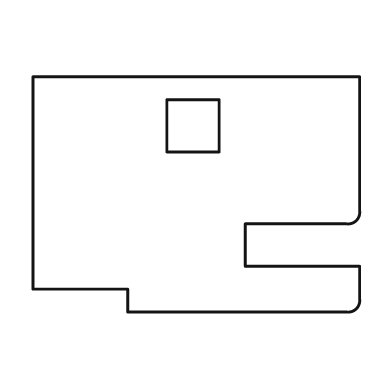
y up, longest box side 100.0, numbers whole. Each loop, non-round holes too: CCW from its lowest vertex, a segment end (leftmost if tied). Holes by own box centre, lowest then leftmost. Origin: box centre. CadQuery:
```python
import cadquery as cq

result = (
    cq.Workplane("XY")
    .moveTo(-21.0, -36.0)
    .lineTo(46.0, -36.0)
    .threePointArc((49.0, -35.0), (50.0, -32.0))
    .lineTo(50.0, -22.0)
    .lineTo(15.0, -22.0)
    .lineTo(15.0, -9.0)
    .lineTo(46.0, -9.0)
    .threePointArc((49.0, -8.0), (50.0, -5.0))
    .lineTo(50.0, 36.0)
    .lineTo(-50.0, 36.0)
    .lineTo(-50.0, -29.0)
    .lineTo(-21.0, -29.0)
    .close()
    .moveTo(-9.0, 13.0)
    .lineTo(7.0, 13.0)
    .lineTo(7.0, 29.0)
    .lineTo(-9.0, 29.0)
    .close()
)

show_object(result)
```